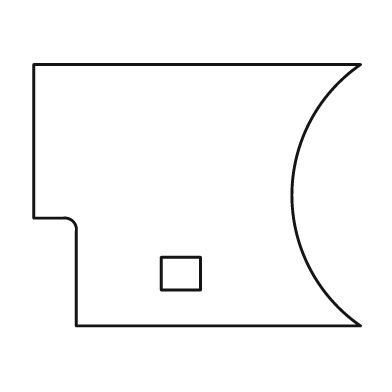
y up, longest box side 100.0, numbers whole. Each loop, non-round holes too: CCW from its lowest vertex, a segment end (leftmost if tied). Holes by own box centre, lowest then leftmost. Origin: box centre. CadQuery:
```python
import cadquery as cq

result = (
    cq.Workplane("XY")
    .moveTo(-37.0, -40.0)
    .lineTo(50.0, -40.0)
    .threePointArc((29.0, 0.0), (50.0, 40.0))
    .lineTo(-50.0, 40.0)
    .lineTo(-50.0, -7.0)
    .lineTo(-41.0, -7.0)
    .threePointArc((-38.0, -8.0), (-37.0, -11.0))
    .close()
    .moveTo(-11.0, -29.0)
    .lineTo(1.0, -29.0)
    .lineTo(1.0, -19.0)
    .lineTo(-11.0, -19.0)
    .close()
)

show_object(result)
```